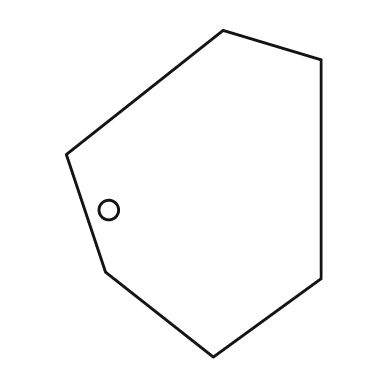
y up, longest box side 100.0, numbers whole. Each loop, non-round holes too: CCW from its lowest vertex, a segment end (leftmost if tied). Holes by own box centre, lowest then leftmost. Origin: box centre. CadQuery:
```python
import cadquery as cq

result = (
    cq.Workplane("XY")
    .moveTo(6.0, -50.0)
    .lineTo(39.0, -26.0)
    .lineTo(39.0, 41.0)
    .lineTo(9.0, 50.0)
    .lineTo(-39.0, 12.0)
    .lineTo(-27.0, -24.0)
    .close()
    .moveTo(-26.0, -5.0)
    .circle(3.0)
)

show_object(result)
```